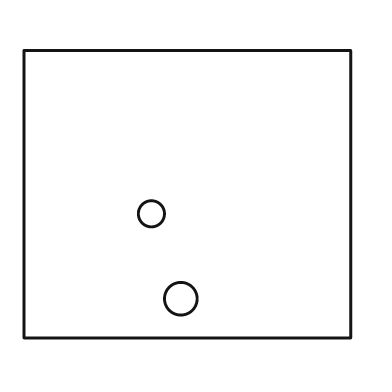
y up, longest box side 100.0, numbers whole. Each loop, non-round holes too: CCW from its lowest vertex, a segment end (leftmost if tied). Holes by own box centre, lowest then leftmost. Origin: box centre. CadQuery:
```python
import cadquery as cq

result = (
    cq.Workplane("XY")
    .moveTo(-50.0, -44.0)
    .lineTo(50.0, -44.0)
    .lineTo(50.0, 44.0)
    .lineTo(-50.0, 44.0)
    .close()
    .moveTo(-2.0, -32.0)
    .circle(5.0)
    .moveTo(-11.0, -6.0)
    .circle(4.0)
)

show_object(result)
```